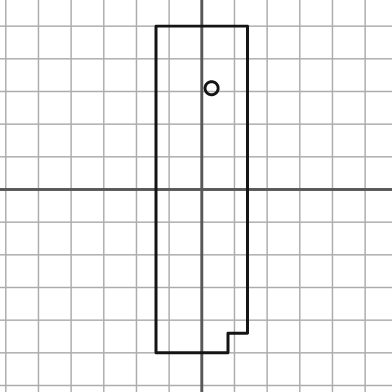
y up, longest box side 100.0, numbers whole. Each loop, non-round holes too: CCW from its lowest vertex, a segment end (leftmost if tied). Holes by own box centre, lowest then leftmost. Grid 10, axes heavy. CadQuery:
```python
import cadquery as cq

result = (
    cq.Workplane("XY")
    .moveTo(-14.0, -50.0)
    .lineTo(8.0, -50.0)
    .lineTo(8.0, -44.0)
    .lineTo(14.0, -44.0)
    .lineTo(14.0, 50.0)
    .lineTo(-14.0, 50.0)
    .close()
    .moveTo(3.0, 31.0)
    .circle(2.0)
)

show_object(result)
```